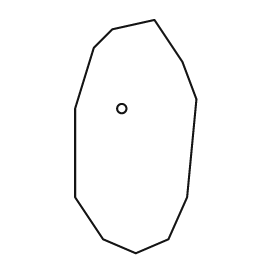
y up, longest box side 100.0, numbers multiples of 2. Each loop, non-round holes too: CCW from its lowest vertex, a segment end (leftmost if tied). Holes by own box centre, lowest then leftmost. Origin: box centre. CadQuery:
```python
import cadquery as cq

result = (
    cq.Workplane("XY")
    .moveTo(0.0, -50.0)
    .lineTo(14.0, -44.0)
    .lineTo(22.0, -26.0)
    .lineTo(26.0, 16.0)
    .lineTo(20.0, 32.0)
    .lineTo(8.0, 50.0)
    .lineTo(-10.0, 46.0)
    .lineTo(-18.0, 38.0)
    .lineTo(-26.0, 12.0)
    .lineTo(-26.0, -26.0)
    .lineTo(-14.0, -44.0)
    .close()
    .moveTo(-6.0, 12.0)
    .circle(2.0)
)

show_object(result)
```